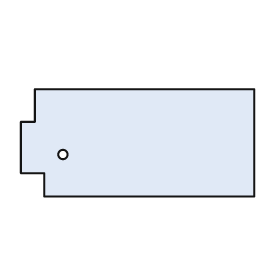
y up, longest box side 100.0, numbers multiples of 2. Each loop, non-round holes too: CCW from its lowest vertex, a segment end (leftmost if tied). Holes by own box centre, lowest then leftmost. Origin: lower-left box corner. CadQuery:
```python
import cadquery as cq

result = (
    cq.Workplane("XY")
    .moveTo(10.0, 0.0)
    .lineTo(100.0, 0.0)
    .lineTo(100.0, 46.0)
    .lineTo(6.0, 46.0)
    .lineTo(6.0, 32.0)
    .lineTo(0.0, 32.0)
    .lineTo(0.0, 10.0)
    .lineTo(10.0, 10.0)
    .close()
    .moveTo(18.0, 18.0)
    .circle(2.0)
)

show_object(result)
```